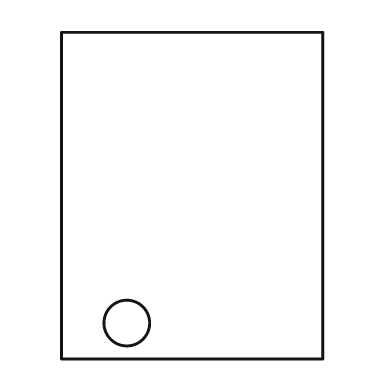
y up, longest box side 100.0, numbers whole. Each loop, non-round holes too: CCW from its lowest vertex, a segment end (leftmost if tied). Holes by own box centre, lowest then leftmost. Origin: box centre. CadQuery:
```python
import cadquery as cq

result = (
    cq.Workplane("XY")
    .moveTo(-40.0, -50.0)
    .lineTo(40.0, -50.0)
    .lineTo(40.0, 50.0)
    .lineTo(-40.0, 50.0)
    .close()
    .moveTo(-20.0, -39.0)
    .circle(7.0)
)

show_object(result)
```